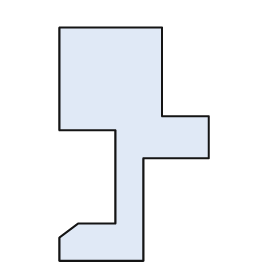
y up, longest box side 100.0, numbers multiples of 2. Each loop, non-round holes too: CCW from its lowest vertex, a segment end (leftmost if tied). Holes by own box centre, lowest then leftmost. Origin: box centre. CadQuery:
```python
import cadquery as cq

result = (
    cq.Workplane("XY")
    .moveTo(-32.0, -50.0)
    .lineTo(4.0, -50.0)
    .lineTo(4.0, -6.0)
    .lineTo(32.0, -6.0)
    .lineTo(32.0, 12.0)
    .lineTo(12.0, 12.0)
    .lineTo(12.0, 50.0)
    .lineTo(-32.0, 50.0)
    .lineTo(-32.0, 6.0)
    .lineTo(-8.0, 6.0)
    .lineTo(-8.0, -34.0)
    .lineTo(-24.0, -34.0)
    .lineTo(-32.0, -40.0)
    .close()
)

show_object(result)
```